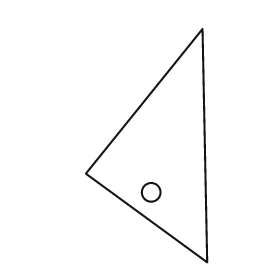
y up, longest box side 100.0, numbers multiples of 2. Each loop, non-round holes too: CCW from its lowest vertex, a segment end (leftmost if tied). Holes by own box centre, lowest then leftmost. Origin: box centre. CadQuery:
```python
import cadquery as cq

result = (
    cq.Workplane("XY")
    .moveTo(26.0, -50.0)
    .lineTo(24.0, 50.0)
    .lineTo(-26.0, -12.0)
    .close()
    .moveTo(2.0, -20.0)
    .circle(4.0)
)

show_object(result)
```